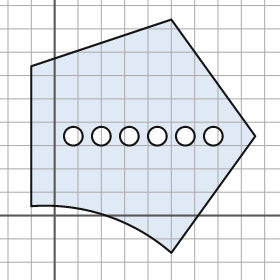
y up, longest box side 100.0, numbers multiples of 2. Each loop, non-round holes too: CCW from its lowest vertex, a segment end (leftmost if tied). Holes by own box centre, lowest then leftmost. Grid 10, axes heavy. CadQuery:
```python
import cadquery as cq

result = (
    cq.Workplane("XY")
    .moveTo(50.0, -16.0)
    .lineTo(86.0, 34.0)
    .lineTo(50.0, 84.0)
    .lineTo(-10.0, 64.0)
    .lineTo(-10.0, 4.0)
    .threePointArc((22.0, 0.0), (50.0, -16.0))
    .close()
    .moveTo(8.0, 34.0)
    .circle(4.0)
    .moveTo(20.0, 34.0)
    .circle(4.0)
    .moveTo(32.0, 34.0)
    .circle(4.0)
    .moveTo(44.0, 34.0)
    .circle(4.0)
    .moveTo(56.0, 34.0)
    .circle(4.0)
    .moveTo(68.0, 34.0)
    .circle(4.0)
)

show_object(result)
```